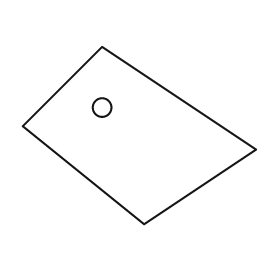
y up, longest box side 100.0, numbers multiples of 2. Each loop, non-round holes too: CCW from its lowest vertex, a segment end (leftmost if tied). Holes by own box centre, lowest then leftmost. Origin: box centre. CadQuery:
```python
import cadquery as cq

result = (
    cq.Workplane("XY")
    .moveTo(2.0, -38.0)
    .lineTo(50.0, -6.0)
    .lineTo(-16.0, 38.0)
    .lineTo(-50.0, 4.0)
    .close()
    .moveTo(-16.0, 12.0)
    .circle(4.0)
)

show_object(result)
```